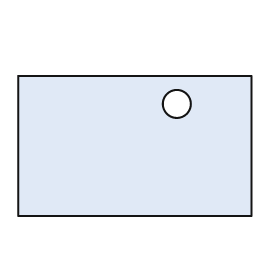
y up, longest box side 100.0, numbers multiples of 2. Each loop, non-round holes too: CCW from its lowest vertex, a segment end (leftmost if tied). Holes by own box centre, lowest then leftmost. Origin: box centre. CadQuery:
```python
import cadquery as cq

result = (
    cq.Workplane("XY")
    .moveTo(-50.0, -30.0)
    .lineTo(50.0, -30.0)
    .lineTo(50.0, 30.0)
    .lineTo(-50.0, 30.0)
    .close()
    .moveTo(18.0, 18.0)
    .circle(6.0)
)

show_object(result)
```